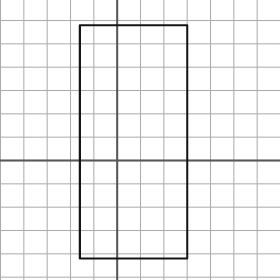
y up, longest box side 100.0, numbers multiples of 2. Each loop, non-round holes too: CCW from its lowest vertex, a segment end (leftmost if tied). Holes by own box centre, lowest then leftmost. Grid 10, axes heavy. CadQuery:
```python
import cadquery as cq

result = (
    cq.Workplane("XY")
    .moveTo(-16.0, -42.0)
    .lineTo(30.0, -42.0)
    .lineTo(30.0, 58.0)
    .lineTo(-16.0, 58.0)
    .close()
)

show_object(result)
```